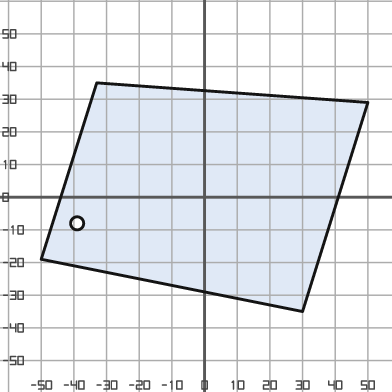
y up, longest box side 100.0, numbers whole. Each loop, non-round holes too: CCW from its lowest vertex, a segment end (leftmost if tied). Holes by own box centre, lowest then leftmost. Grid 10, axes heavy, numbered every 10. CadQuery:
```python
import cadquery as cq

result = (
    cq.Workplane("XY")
    .moveTo(30.0, -35.0)
    .lineTo(50.0, 29.0)
    .lineTo(-33.0, 35.0)
    .lineTo(-50.0, -19.0)
    .close()
    .moveTo(-39.0, -8.0)
    .circle(2.0)
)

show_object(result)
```